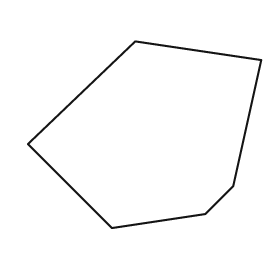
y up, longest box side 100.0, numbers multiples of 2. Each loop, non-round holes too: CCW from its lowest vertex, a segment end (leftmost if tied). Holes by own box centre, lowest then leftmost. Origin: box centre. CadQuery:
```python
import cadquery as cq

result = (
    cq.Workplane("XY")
    .moveTo(-14.0, -40.0)
    .lineTo(26.0, -34.0)
    .lineTo(38.0, -22.0)
    .lineTo(50.0, 32.0)
    .lineTo(-4.0, 40.0)
    .lineTo(-50.0, -4.0)
    .close()
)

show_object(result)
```